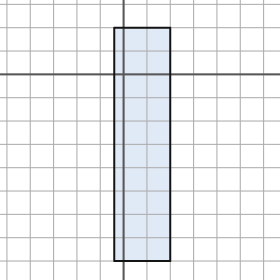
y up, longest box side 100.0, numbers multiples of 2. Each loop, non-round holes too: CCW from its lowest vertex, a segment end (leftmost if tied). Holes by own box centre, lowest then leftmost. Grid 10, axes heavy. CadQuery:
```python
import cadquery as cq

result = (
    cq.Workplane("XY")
    .moveTo(-4.0, -80.0)
    .lineTo(20.0, -80.0)
    .lineTo(20.0, 20.0)
    .lineTo(-4.0, 20.0)
    .close()
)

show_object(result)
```